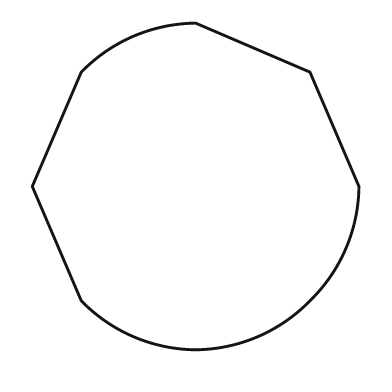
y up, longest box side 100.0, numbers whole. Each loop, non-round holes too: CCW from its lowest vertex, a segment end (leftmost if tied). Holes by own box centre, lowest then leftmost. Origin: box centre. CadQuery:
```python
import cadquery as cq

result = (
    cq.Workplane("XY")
    .moveTo(0.0, -50.0)
    .threePointArc((19.0, -46.0), (35.0, -35.0))
    .threePointArc((46.0, -19.0), (50.0, 0.0))
    .lineTo(35.0, 35.0)
    .lineTo(0.0, 50.0)
    .threePointArc((-19.0, 46.0), (-35.0, 35.0))
    .lineTo(-50.0, 0.0)
    .lineTo(-35.0, -35.0)
    .threePointArc((-19.0, -46.0), (0.0, -50.0))
    .close()
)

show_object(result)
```